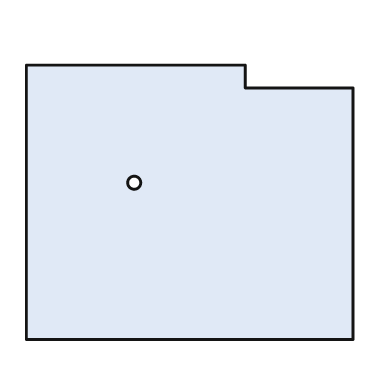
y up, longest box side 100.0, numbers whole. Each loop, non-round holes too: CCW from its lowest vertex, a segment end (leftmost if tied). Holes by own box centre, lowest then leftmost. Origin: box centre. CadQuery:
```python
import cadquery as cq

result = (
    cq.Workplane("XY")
    .moveTo(-50.0, -42.0)
    .lineTo(50.0, -42.0)
    .lineTo(50.0, 35.0)
    .lineTo(17.0, 35.0)
    .lineTo(17.0, 42.0)
    .lineTo(-50.0, 42.0)
    .close()
    .moveTo(-17.0, 6.0)
    .circle(2.0)
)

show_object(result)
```